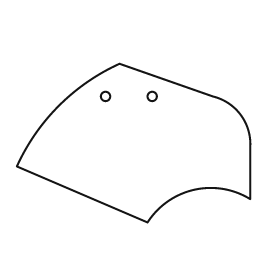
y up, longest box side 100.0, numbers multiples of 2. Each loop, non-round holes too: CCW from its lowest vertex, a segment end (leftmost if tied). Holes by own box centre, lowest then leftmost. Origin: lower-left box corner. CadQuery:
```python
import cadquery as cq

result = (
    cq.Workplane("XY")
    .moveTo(56.0, 0.0)
    .threePointArc((76.0, 14.0), (100.0, 10.0))
    .lineTo(100.0, 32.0)
    .threePointArc((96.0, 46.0), (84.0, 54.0))
    .lineTo(44.0, 68.0)
    .threePointArc((18.0, 50.0), (0.0, 24.0))
    .close()
    .moveTo(38.0, 54.0)
    .circle(2.0)
    .moveTo(58.0, 54.0)
    .circle(2.0)
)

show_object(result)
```